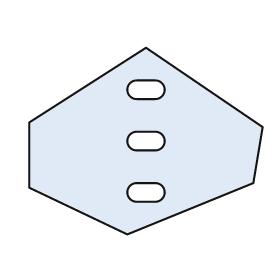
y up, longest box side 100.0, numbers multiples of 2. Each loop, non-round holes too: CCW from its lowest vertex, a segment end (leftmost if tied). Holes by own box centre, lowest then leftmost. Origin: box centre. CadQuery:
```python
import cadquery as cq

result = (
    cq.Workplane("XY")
    .moveTo(-8.0, -40.0)
    .lineTo(46.0, -18.0)
    .lineTo(50.0, 6.0)
    .lineTo(0.0, 40.0)
    .lineTo(-50.0, 8.0)
    .lineTo(-50.0, -20.0)
    .close()
    .moveTo(-4.0, -26.0)
    .lineTo(4.0, -26.0)
    .threePointArc((8.0, -22.0), (4.0, -18.0))
    .lineTo(-4.0, -18.0)
    .threePointArc((-8.0, -22.0), (-4.0, -26.0))
    .close()
    .moveTo(-4.0, -4.0)
    .lineTo(4.0, -4.0)
    .threePointArc((8.0, 0.0), (4.0, 4.0))
    .lineTo(-4.0, 4.0)
    .threePointArc((-8.0, 0.0), (-4.0, -4.0))
    .close()
    .moveTo(-4.0, 18.0)
    .lineTo(4.0, 18.0)
    .threePointArc((8.0, 22.0), (4.0, 26.0))
    .lineTo(-4.0, 26.0)
    .threePointArc((-8.0, 22.0), (-4.0, 18.0))
    .close()
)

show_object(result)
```